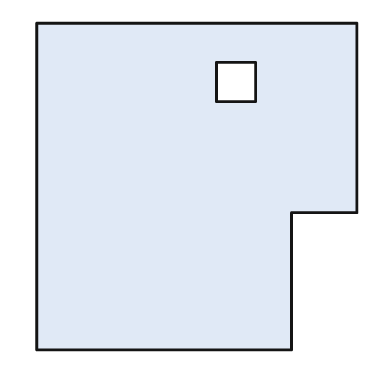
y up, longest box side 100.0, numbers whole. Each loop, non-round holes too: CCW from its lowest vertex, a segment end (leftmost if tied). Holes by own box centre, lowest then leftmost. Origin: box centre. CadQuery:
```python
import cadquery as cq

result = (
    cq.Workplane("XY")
    .moveTo(-49.0, -50.0)
    .lineTo(29.0, -50.0)
    .lineTo(29.0, -8.0)
    .lineTo(49.0, -8.0)
    .lineTo(49.0, 50.0)
    .lineTo(-49.0, 50.0)
    .close()
    .moveTo(6.0, 26.0)
    .lineTo(18.0, 26.0)
    .lineTo(18.0, 38.0)
    .lineTo(6.0, 38.0)
    .close()
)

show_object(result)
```